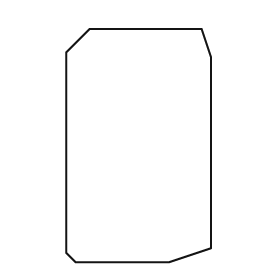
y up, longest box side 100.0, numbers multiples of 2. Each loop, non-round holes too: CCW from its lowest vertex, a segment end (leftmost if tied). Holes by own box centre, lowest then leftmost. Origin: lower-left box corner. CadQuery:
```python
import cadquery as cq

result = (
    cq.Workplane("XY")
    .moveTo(4.0, 0.0)
    .lineTo(44.0, 0.0)
    .lineTo(62.0, 6.0)
    .lineTo(62.0, 88.0)
    .lineTo(58.0, 100.0)
    .lineTo(10.0, 100.0)
    .lineTo(0.0, 90.0)
    .lineTo(0.0, 4.0)
    .close()
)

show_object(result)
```